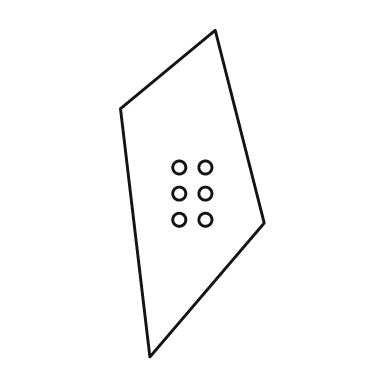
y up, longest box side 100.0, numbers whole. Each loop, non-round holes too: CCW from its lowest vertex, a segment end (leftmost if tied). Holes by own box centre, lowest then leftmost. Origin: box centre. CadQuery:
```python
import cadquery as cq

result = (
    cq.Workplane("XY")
    .moveTo(-13.0, -50.0)
    .lineTo(22.0, -9.0)
    .lineTo(7.0, 50.0)
    .lineTo(-22.0, 26.0)
    .close()
    .moveTo(-4.0, -8.0)
    .circle(2.0)
    .moveTo(4.0, -8.0)
    .circle(2.0)
    .moveTo(-4.0, 0.0)
    .circle(2.0)
    .moveTo(4.0, 0.0)
    .circle(2.0)
    .moveTo(-4.0, 8.0)
    .circle(2.0)
    .moveTo(4.0, 8.0)
    .circle(2.0)
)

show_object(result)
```